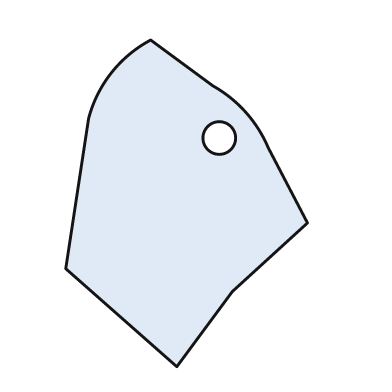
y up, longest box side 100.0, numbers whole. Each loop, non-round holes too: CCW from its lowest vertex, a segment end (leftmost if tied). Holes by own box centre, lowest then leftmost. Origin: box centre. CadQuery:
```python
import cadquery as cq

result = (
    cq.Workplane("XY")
    .moveTo(-3.0, -50.0)
    .lineTo(14.0, -27.0)
    .lineTo(37.0, -6.0)
    .lineTo(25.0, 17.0)
    .threePointArc((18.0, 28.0), (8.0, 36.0))
    .lineTo(-11.0, 50.0)
    .threePointArc((-23.0, 40.0), (-30.0, 26.0))
    .lineTo(-37.0, -20.0)
    .close()
    .moveTo(10.0, 20.0)
    .circle(5.0)
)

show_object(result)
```